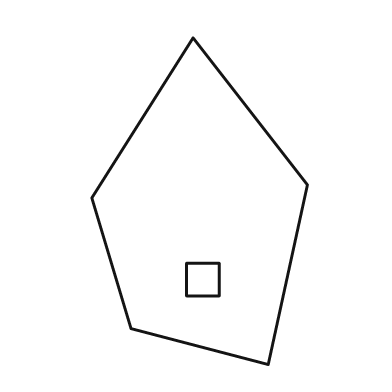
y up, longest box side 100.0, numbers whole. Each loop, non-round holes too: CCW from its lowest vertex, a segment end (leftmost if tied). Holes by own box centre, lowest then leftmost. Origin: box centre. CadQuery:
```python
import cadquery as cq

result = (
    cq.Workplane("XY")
    .moveTo(21.0, -50.0)
    .lineTo(33.0, 5.0)
    .lineTo(-2.0, 50.0)
    .lineTo(-33.0, 1.0)
    .lineTo(-21.0, -39.0)
    .close()
    .moveTo(-4.0, -29.0)
    .lineTo(6.0, -29.0)
    .lineTo(6.0, -19.0)
    .lineTo(-4.0, -19.0)
    .close()
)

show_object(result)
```